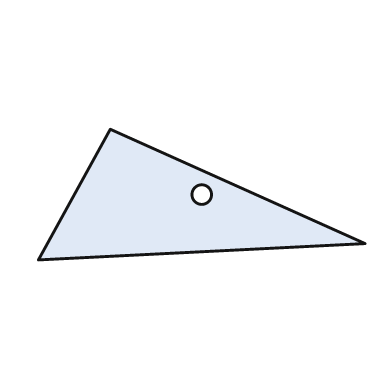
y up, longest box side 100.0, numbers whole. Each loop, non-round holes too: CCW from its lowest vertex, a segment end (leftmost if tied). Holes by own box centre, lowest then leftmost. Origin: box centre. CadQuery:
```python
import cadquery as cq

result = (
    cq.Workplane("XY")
    .moveTo(-50.0, -20.0)
    .lineTo(50.0, -15.0)
    .lineTo(-28.0, 20.0)
    .close()
    .moveTo(0.0, 0.0)
    .circle(3.0)
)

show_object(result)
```